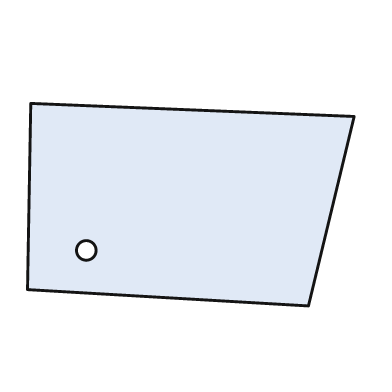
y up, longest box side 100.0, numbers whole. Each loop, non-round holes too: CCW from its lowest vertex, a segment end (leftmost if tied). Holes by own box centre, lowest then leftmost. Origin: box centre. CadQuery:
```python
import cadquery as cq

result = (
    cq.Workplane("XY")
    .moveTo(36.0, -31.0)
    .lineTo(50.0, 27.0)
    .lineTo(-49.0, 31.0)
    .lineTo(-50.0, -26.0)
    .close()
    .moveTo(-32.0, -14.0)
    .circle(3.0)
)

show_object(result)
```